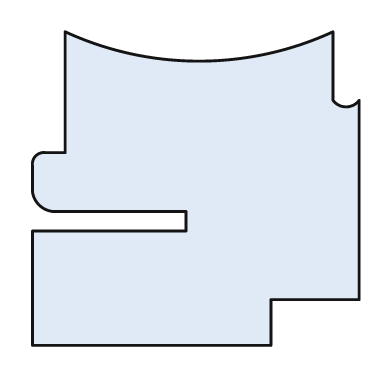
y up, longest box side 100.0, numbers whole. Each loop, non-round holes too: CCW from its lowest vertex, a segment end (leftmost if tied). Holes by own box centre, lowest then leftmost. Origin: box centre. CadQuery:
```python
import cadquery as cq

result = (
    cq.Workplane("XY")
    .moveTo(-50.0, -48.0)
    .lineTo(23.0, -48.0)
    .lineTo(23.0, -34.0)
    .lineTo(50.0, -34.0)
    .lineTo(50.0, 27.0)
    .threePointArc((46.0, 25.0), (42.0, 27.0))
    .lineTo(42.0, 48.0)
    .threePointArc((1.0, 39.0), (-40.0, 48.0))
    .lineTo(-40.0, 11.0)
    .lineTo(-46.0, 11.0)
    .threePointArc((-49.0, 10.0), (-50.0, 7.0))
    .lineTo(-50.0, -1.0)
    .threePointArc((-48.0, -5.0), (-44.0, -7.0))
    .lineTo(-3.0, -7.0)
    .lineTo(-3.0, -13.0)
    .lineTo(-50.0, -13.0)
    .close()
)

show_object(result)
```